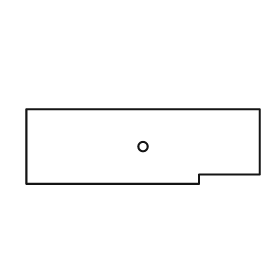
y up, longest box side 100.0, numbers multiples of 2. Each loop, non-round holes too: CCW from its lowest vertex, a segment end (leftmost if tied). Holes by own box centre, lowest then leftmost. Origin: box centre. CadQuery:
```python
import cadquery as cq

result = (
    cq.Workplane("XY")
    .moveTo(-50.0, -16.0)
    .lineTo(24.0, -16.0)
    .lineTo(24.0, -12.0)
    .lineTo(50.0, -12.0)
    .lineTo(50.0, 16.0)
    .lineTo(-50.0, 16.0)
    .close()
    .moveTo(0.0, 0.0)
    .circle(2.0)
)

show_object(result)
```